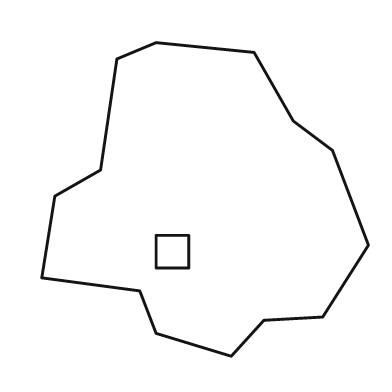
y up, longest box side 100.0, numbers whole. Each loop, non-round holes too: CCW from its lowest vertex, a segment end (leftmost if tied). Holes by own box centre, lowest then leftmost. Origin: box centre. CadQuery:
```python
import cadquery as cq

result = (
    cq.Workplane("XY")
    .moveTo(8.0, -48.0)
    .lineTo(18.0, -37.0)
    .lineTo(36.0, -36.0)
    .lineTo(50.0, -14.0)
    .lineTo(39.0, 15.0)
    .lineTo(27.0, 24.0)
    .lineTo(15.0, 45.0)
    .lineTo(-15.0, 48.0)
    .lineTo(-27.0, 43.0)
    .lineTo(-32.0, 9.0)
    .lineTo(-46.0, 1.0)
    .lineTo(-50.0, -24.0)
    .lineTo(-20.0, -28.0)
    .lineTo(-15.0, -41.0)
    .close()
    .moveTo(-15.0, -21.0)
    .lineTo(-5.0, -21.0)
    .lineTo(-5.0, -11.0)
    .lineTo(-15.0, -11.0)
    .close()
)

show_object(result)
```